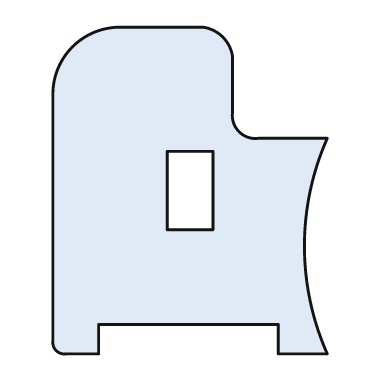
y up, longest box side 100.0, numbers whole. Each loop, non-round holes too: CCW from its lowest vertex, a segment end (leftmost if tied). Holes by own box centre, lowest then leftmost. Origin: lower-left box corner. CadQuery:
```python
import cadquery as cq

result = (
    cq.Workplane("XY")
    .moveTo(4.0, 0.0)
    .lineTo(14.0, 0.0)
    .lineTo(14.0, 9.0)
    .lineTo(69.0, 9.0)
    .lineTo(69.0, 0.0)
    .lineTo(84.0, 0.0)
    .threePointArc((77.0, 33.0), (84.0, 66.0))
    .lineTo(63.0, 66.0)
    .threePointArc((57.0, 68.0), (55.0, 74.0))
    .lineTo(55.0, 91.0)
    .threePointArc((52.0, 97.0), (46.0, 100.0))
    .lineTo(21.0, 100.0)
    .threePointArc((6.0, 94.0), (0.0, 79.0))
    .lineTo(0.0, 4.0)
    .threePointArc((1.0, 1.0), (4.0, 0.0))
    .close()
    .moveTo(35.0, 38.0)
    .lineTo(49.0, 38.0)
    .lineTo(49.0, 62.0)
    .lineTo(35.0, 62.0)
    .close()
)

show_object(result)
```